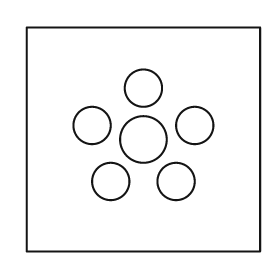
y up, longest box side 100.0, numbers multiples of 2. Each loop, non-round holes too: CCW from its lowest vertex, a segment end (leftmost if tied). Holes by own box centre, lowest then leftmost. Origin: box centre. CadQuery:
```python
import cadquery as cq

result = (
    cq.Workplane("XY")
    .moveTo(-50.0, -48.0)
    .lineTo(50.0, -48.0)
    .lineTo(50.0, 48.0)
    .lineTo(-50.0, 48.0)
    .close()
    .moveTo(-14.0, -18.0)
    .circle(8.0)
    .moveTo(14.0, -18.0)
    .circle(8.0)
    .moveTo(0.0, 0.0)
    .circle(10.0)
    .moveTo(-22.0, 6.0)
    .circle(8.0)
    .moveTo(22.0, 6.0)
    .circle(8.0)
    .moveTo(0.0, 22.0)
    .circle(8.0)
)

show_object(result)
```